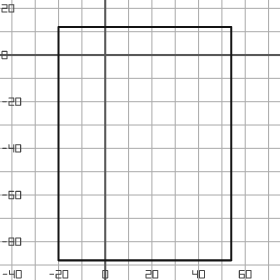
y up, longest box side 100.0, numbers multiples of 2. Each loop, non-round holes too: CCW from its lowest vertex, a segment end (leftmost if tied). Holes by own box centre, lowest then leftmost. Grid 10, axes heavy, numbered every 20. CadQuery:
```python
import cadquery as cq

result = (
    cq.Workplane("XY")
    .moveTo(-20.0, -88.0)
    .lineTo(54.0, -88.0)
    .lineTo(54.0, 12.0)
    .lineTo(-20.0, 12.0)
    .close()
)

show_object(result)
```